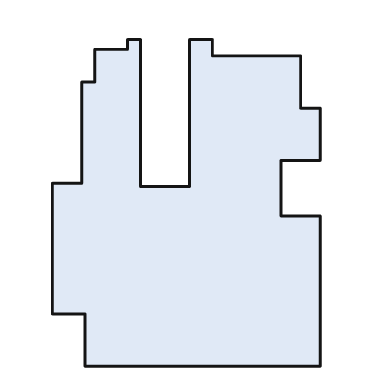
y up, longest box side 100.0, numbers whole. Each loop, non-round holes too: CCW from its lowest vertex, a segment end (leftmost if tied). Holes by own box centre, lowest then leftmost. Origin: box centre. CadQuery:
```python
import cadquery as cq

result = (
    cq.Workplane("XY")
    .moveTo(-31.0, -50.0)
    .lineTo(41.0, -50.0)
    .lineTo(41.0, -4.0)
    .lineTo(29.0, -4.0)
    .lineTo(29.0, 13.0)
    .lineTo(41.0, 13.0)
    .lineTo(41.0, 29.0)
    .lineTo(35.0, 29.0)
    .lineTo(35.0, 45.0)
    .lineTo(8.0, 45.0)
    .lineTo(8.0, 50.0)
    .lineTo(1.0, 50.0)
    .lineTo(1.0, 5.0)
    .lineTo(-14.0, 5.0)
    .lineTo(-14.0, 50.0)
    .lineTo(-18.0, 50.0)
    .lineTo(-18.0, 47.0)
    .lineTo(-28.0, 47.0)
    .lineTo(-28.0, 37.0)
    .lineTo(-32.0, 37.0)
    .lineTo(-32.0, 6.0)
    .lineTo(-41.0, 6.0)
    .lineTo(-41.0, -34.0)
    .lineTo(-31.0, -34.0)
    .close()
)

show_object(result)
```